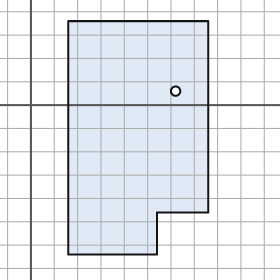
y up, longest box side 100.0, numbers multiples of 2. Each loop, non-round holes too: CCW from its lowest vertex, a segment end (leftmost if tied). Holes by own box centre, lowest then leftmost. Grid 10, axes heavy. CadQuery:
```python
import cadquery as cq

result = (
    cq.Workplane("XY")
    .moveTo(16.0, -64.0)
    .lineTo(54.0, -64.0)
    .lineTo(54.0, -46.0)
    .lineTo(76.0, -46.0)
    .lineTo(76.0, 36.0)
    .lineTo(16.0, 36.0)
    .close()
    .moveTo(62.0, 6.0)
    .circle(2.0)
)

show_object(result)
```